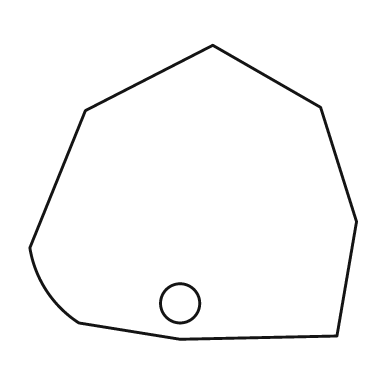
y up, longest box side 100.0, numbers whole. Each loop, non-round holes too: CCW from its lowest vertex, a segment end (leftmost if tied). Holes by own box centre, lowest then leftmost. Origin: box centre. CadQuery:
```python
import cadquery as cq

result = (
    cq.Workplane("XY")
    .moveTo(-4.0, -45.0)
    .lineTo(44.0, -44.0)
    .lineTo(50.0, -9.0)
    .lineTo(39.0, 26.0)
    .lineTo(6.0, 45.0)
    .lineTo(-33.0, 25.0)
    .lineTo(-50.0, -17.0)
    .threePointArc((-45.0, -30.0), (-35.0, -40.0))
    .close()
    .moveTo(-4.0, -34.0)
    .circle(6.0)
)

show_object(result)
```